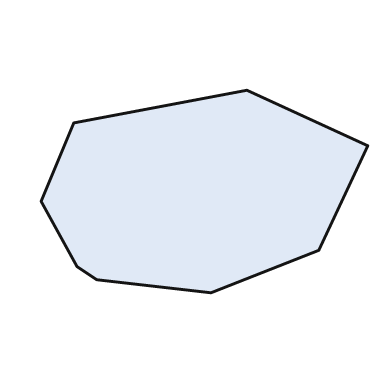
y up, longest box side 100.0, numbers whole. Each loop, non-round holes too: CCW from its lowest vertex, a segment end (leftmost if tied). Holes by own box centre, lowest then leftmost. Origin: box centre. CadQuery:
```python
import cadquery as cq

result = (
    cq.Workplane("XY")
    .moveTo(2.0, -31.0)
    .lineTo(35.0, -18.0)
    .lineTo(50.0, 14.0)
    .lineTo(13.0, 31.0)
    .lineTo(-40.0, 21.0)
    .lineTo(-50.0, -3.0)
    .lineTo(-39.0, -23.0)
    .lineTo(-33.0, -27.0)
    .close()
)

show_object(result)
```